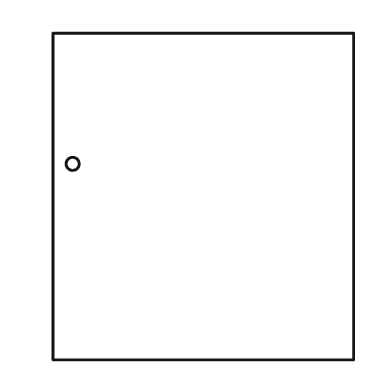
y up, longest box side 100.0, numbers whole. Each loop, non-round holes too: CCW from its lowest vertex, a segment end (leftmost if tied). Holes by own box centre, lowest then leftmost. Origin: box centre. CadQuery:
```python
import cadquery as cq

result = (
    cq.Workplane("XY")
    .moveTo(-46.0, -50.0)
    .lineTo(46.0, -50.0)
    .lineTo(46.0, 50.0)
    .lineTo(-46.0, 50.0)
    .close()
    .moveTo(-40.0, 10.0)
    .circle(2.0)
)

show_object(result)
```